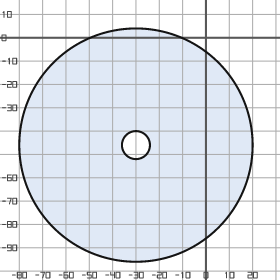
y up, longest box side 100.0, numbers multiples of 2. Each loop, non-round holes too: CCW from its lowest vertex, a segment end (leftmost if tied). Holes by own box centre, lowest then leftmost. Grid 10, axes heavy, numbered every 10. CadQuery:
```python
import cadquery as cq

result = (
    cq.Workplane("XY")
    .moveTo(-30.0, -46.0)
    .circle(50.0)
    .moveTo(-30.0, -46.0)
    .circle(6.0)
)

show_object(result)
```